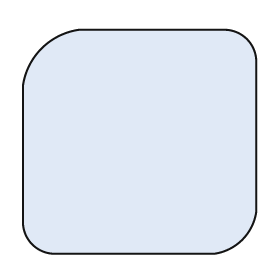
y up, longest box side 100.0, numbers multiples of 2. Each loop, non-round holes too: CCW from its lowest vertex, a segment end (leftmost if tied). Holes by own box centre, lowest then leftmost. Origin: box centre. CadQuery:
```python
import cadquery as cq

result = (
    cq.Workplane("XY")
    .moveTo(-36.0, -48.0)
    .lineTo(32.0, -48.0)
    .threePointArc((44.0, -42.0), (50.0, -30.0))
    .lineTo(50.0, 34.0)
    .threePointArc((46.0, 44.0), (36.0, 48.0))
    .lineTo(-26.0, 48.0)
    .threePointArc((-42.0, 40.0), (-50.0, 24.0))
    .lineTo(-50.0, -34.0)
    .threePointArc((-46.0, -44.0), (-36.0, -48.0))
    .close()
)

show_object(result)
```